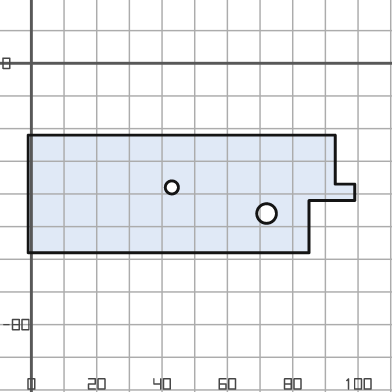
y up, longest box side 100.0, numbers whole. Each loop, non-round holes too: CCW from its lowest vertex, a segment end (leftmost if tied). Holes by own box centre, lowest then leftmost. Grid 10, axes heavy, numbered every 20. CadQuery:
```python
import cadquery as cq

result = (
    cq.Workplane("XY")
    .moveTo(-1.0, -58.0)
    .lineTo(85.0, -58.0)
    .lineTo(85.0, -42.0)
    .lineTo(99.0, -42.0)
    .lineTo(99.0, -37.0)
    .lineTo(93.0, -37.0)
    .lineTo(93.0, -22.0)
    .lineTo(-1.0, -22.0)
    .close()
    .moveTo(72.0, -46.0)
    .circle(3.0)
    .moveTo(43.0, -38.0)
    .circle(2.0)
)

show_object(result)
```